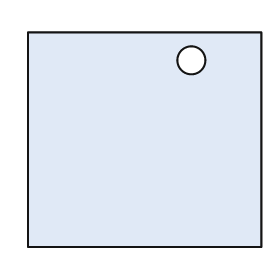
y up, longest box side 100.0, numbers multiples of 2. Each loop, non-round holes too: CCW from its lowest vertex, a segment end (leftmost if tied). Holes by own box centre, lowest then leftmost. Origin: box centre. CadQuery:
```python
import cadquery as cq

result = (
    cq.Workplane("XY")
    .moveTo(-50.0, -46.0)
    .lineTo(50.0, -46.0)
    .lineTo(50.0, 46.0)
    .lineTo(-50.0, 46.0)
    .close()
    .moveTo(20.0, 34.0)
    .circle(6.0)
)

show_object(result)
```